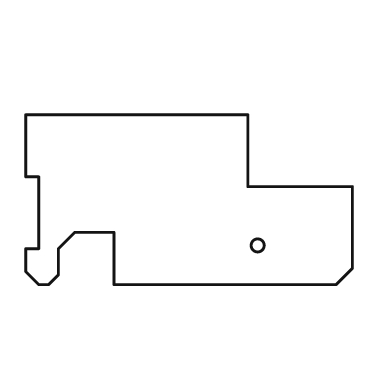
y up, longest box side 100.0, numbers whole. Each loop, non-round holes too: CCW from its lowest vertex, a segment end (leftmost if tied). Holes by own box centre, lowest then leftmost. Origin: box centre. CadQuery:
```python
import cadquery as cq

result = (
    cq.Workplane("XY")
    .moveTo(-46.0, -26.0)
    .lineTo(-43.0, -26.0)
    .lineTo(-40.0, -23.0)
    .lineTo(-40.0, -15.0)
    .lineTo(-35.0, -10.0)
    .lineTo(-23.0, -10.0)
    .lineTo(-23.0, -26.0)
    .lineTo(45.0, -26.0)
    .lineTo(50.0, -21.0)
    .lineTo(50.0, 4.0)
    .lineTo(18.0, 4.0)
    .lineTo(18.0, 26.0)
    .lineTo(-50.0, 26.0)
    .lineTo(-50.0, 7.0)
    .lineTo(-46.0, 7.0)
    .lineTo(-46.0, -15.0)
    .lineTo(-50.0, -15.0)
    .lineTo(-50.0, -22.0)
    .close()
    .moveTo(21.0, -14.0)
    .circle(2.0)
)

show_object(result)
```